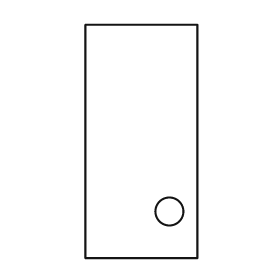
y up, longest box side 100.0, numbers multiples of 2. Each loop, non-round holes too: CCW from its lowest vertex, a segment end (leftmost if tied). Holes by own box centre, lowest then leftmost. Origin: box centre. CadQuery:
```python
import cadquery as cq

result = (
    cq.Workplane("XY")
    .moveTo(-24.0, -50.0)
    .lineTo(24.0, -50.0)
    .lineTo(24.0, 50.0)
    .lineTo(-24.0, 50.0)
    .close()
    .moveTo(12.0, -30.0)
    .circle(6.0)
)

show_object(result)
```